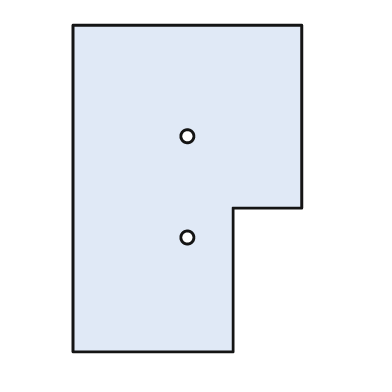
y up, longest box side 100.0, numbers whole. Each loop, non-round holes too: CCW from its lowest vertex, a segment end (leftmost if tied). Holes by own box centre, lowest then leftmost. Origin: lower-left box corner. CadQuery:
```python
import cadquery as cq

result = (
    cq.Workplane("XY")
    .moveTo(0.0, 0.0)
    .lineTo(49.0, 0.0)
    .lineTo(49.0, 44.0)
    .lineTo(70.0, 44.0)
    .lineTo(70.0, 100.0)
    .lineTo(0.0, 100.0)
    .close()
    .moveTo(35.0, 35.0)
    .circle(2.0)
    .moveTo(35.0, 66.0)
    .circle(2.0)
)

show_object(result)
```